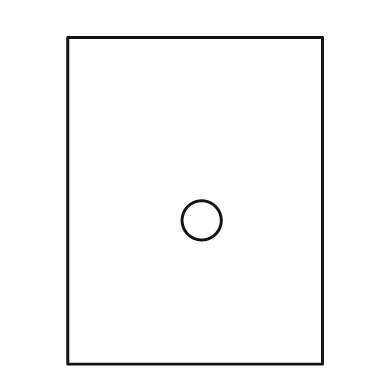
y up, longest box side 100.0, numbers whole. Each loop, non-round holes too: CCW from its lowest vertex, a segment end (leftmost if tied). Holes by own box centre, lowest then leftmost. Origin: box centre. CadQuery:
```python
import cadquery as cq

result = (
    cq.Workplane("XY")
    .moveTo(-39.0, -50.0)
    .lineTo(39.0, -50.0)
    .lineTo(39.0, 50.0)
    .lineTo(-39.0, 50.0)
    .close()
    .moveTo(2.0, -6.0)
    .circle(6.0)
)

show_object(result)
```